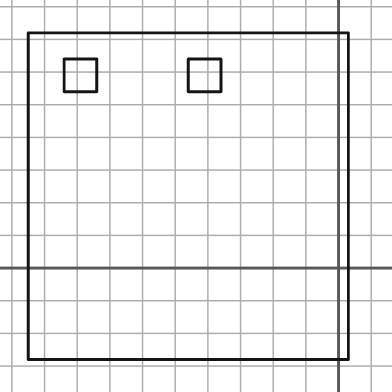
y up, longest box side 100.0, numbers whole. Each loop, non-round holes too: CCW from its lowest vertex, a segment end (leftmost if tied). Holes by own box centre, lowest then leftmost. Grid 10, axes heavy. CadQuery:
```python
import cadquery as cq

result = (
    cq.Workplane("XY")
    .moveTo(-95.0, -28.0)
    .lineTo(3.0, -28.0)
    .lineTo(3.0, 72.0)
    .lineTo(-95.0, 72.0)
    .close()
    .moveTo(-84.0, 54.0)
    .lineTo(-74.0, 54.0)
    .lineTo(-74.0, 64.0)
    .lineTo(-84.0, 64.0)
    .close()
    .moveTo(-46.0, 54.0)
    .lineTo(-36.0, 54.0)
    .lineTo(-36.0, 64.0)
    .lineTo(-46.0, 64.0)
    .close()
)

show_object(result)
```